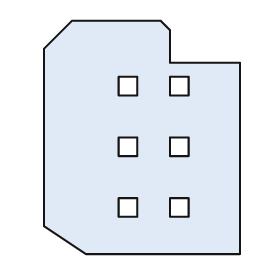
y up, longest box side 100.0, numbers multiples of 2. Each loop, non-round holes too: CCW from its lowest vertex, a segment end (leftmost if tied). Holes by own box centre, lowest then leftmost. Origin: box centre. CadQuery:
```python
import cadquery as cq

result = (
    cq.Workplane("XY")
    .moveTo(-24.0, -50.0)
    .lineTo(42.0, -50.0)
    .lineTo(42.0, 32.0)
    .lineTo(12.0, 32.0)
    .lineTo(12.0, 46.0)
    .lineTo(8.0, 50.0)
    .lineTo(-30.0, 50.0)
    .lineTo(-42.0, 38.0)
    .lineTo(-42.0, -38.0)
    .close()
    .moveTo(-10.0, -34.0)
    .lineTo(-2.0, -34.0)
    .lineTo(-2.0, -26.0)
    .lineTo(-10.0, -26.0)
    .close()
    .moveTo(12.0, -34.0)
    .lineTo(20.0, -34.0)
    .lineTo(20.0, -26.0)
    .lineTo(12.0, -26.0)
    .close()
    .moveTo(-10.0, -8.0)
    .lineTo(-2.0, -8.0)
    .lineTo(-2.0, 0.0)
    .lineTo(-10.0, 0.0)
    .close()
    .moveTo(12.0, -8.0)
    .lineTo(20.0, -8.0)
    .lineTo(20.0, 0.0)
    .lineTo(12.0, 0.0)
    .close()
    .moveTo(-10.0, 18.0)
    .lineTo(-2.0, 18.0)
    .lineTo(-2.0, 26.0)
    .lineTo(-10.0, 26.0)
    .close()
    .moveTo(12.0, 18.0)
    .lineTo(20.0, 18.0)
    .lineTo(20.0, 26.0)
    .lineTo(12.0, 26.0)
    .close()
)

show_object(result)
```